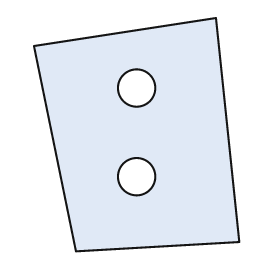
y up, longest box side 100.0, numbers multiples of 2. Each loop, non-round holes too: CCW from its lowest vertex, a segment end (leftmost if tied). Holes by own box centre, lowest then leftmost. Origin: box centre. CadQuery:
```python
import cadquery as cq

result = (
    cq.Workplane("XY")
    .moveTo(-26.0, -50.0)
    .lineTo(44.0, -46.0)
    .lineTo(34.0, 50.0)
    .lineTo(-44.0, 38.0)
    .close()
    .moveTo(0.0, -18.0)
    .circle(8.0)
    .moveTo(0.0, 20.0)
    .circle(8.0)
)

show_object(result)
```